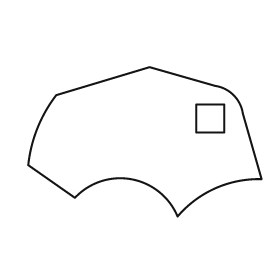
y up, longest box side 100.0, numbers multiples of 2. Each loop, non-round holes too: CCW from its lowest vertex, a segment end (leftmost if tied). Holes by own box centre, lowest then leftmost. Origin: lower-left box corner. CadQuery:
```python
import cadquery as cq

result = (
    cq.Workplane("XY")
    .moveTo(64.0, 0.0)
    .threePointArc((80.0, 12.0), (100.0, 16.0))
    .lineTo(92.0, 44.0)
    .threePointArc((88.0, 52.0), (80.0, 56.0))
    .lineTo(52.0, 64.0)
    .lineTo(12.0, 52.0)
    .threePointArc((4.0, 38.0), (0.0, 22.0))
    .lineTo(20.0, 8.0)
    .threePointArc((44.0, 16.0), (64.0, 0.0))
    .close()
    .moveTo(72.0, 36.0)
    .lineTo(84.0, 36.0)
    .lineTo(84.0, 48.0)
    .lineTo(72.0, 48.0)
    .close()
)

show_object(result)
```